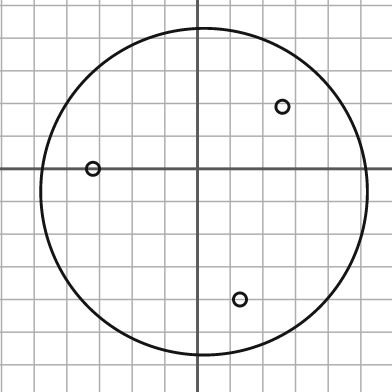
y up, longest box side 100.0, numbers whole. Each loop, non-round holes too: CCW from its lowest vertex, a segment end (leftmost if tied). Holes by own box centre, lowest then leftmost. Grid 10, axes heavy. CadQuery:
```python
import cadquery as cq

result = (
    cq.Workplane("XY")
    .moveTo(2.0, -7.0)
    .circle(50.0)
    .moveTo(13.0, -40.0)
    .circle(2.0)
    .moveTo(-32.0, 0.0)
    .circle(2.0)
    .moveTo(26.0, 19.0)
    .circle(2.0)
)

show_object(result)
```